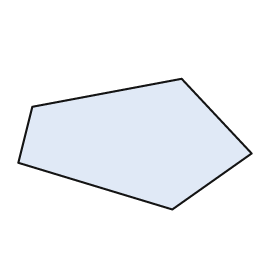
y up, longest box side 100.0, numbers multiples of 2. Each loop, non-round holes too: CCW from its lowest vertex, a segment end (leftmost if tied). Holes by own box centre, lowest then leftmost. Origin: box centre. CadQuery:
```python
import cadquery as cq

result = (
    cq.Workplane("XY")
    .moveTo(16.0, -28.0)
    .lineTo(50.0, -4.0)
    .lineTo(20.0, 28.0)
    .lineTo(-44.0, 16.0)
    .lineTo(-50.0, -8.0)
    .close()
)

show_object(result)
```